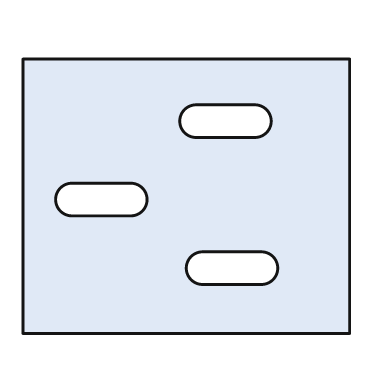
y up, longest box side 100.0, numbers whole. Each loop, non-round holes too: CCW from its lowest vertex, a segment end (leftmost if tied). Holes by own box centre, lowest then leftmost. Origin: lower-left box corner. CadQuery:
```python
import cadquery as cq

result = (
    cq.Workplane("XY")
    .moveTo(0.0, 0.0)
    .lineTo(100.0, 0.0)
    .lineTo(100.0, 84.0)
    .lineTo(0.0, 84.0)
    .close()
    .moveTo(55.0, 15.0)
    .lineTo(73.0, 15.0)
    .threePointArc((78.0, 20.0), (73.0, 25.0))
    .lineTo(55.0, 25.0)
    .threePointArc((50.0, 20.0), (55.0, 15.0))
    .close()
    .moveTo(15.0, 36.0)
    .lineTo(33.0, 36.0)
    .threePointArc((38.0, 41.0), (33.0, 46.0))
    .lineTo(15.0, 46.0)
    .threePointArc((10.0, 41.0), (15.0, 36.0))
    .close()
    .moveTo(53.0, 60.0)
    .lineTo(71.0, 60.0)
    .threePointArc((76.0, 65.0), (71.0, 70.0))
    .lineTo(53.0, 70.0)
    .threePointArc((48.0, 65.0), (53.0, 60.0))
    .close()
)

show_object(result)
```